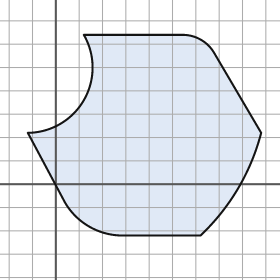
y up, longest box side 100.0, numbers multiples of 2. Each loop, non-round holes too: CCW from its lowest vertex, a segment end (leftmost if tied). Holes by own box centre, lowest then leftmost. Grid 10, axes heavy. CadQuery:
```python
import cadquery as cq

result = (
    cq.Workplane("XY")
    .moveTo(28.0, -22.0)
    .lineTo(62.0, -22.0)
    .threePointArc((78.0, -2.0), (88.0, 22.0))
    .lineTo(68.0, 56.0)
    .threePointArc((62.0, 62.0), (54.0, 64.0))
    .lineTo(12.0, 64.0)
    .threePointArc((12.0, 36.0), (-12.0, 22.0))
    .lineTo(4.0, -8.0)
    .threePointArc((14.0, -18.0), (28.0, -22.0))
    .close()
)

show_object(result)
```